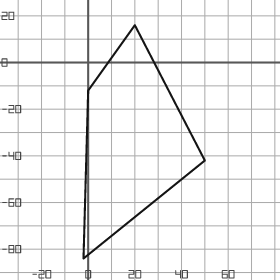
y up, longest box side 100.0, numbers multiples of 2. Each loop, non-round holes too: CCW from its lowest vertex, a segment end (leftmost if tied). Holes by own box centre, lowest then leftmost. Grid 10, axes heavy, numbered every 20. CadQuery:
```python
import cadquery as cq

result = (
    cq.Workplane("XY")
    .moveTo(-2.0, -84.0)
    .lineTo(50.0, -42.0)
    .lineTo(20.0, 16.0)
    .lineTo(0.0, -12.0)
    .close()
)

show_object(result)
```